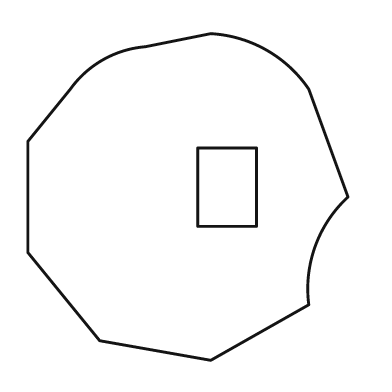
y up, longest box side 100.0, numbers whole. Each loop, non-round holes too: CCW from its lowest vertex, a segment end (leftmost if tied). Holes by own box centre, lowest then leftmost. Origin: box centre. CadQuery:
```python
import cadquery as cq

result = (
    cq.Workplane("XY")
    .moveTo(7.0, -50.0)
    .lineTo(37.0, -33.0)
    .threePointArc((39.0, -15.0), (49.0, 0.0))
    .lineTo(37.0, 33.0)
    .threePointArc((24.0, 45.0), (7.0, 50.0))
    .lineTo(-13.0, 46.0)
    .threePointArc((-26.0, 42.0), (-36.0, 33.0))
    .lineTo(-49.0, 17.0)
    .lineTo(-49.0, -17.0)
    .lineTo(-27.0, -44.0)
    .close()
    .moveTo(3.0, -9.0)
    .lineTo(21.0, -9.0)
    .lineTo(21.0, 15.0)
    .lineTo(3.0, 15.0)
    .close()
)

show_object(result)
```